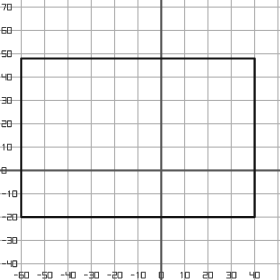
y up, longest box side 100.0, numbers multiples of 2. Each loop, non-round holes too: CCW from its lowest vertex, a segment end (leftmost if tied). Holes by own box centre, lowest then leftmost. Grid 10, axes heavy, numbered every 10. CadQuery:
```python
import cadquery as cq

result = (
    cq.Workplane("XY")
    .moveTo(-60.0, -20.0)
    .lineTo(40.0, -20.0)
    .lineTo(40.0, 48.0)
    .lineTo(-60.0, 48.0)
    .close()
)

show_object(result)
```